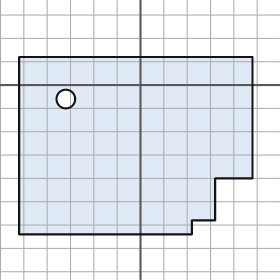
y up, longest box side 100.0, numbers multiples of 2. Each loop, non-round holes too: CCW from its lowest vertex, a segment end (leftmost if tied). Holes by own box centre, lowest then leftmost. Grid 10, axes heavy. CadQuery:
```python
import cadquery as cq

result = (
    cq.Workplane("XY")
    .moveTo(-52.0, -64.0)
    .lineTo(22.0, -64.0)
    .lineTo(22.0, -58.0)
    .lineTo(32.0, -58.0)
    .lineTo(32.0, -40.0)
    .lineTo(48.0, -40.0)
    .lineTo(48.0, 12.0)
    .lineTo(-52.0, 12.0)
    .close()
    .moveTo(-32.0, -6.0)
    .circle(4.0)
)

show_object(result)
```